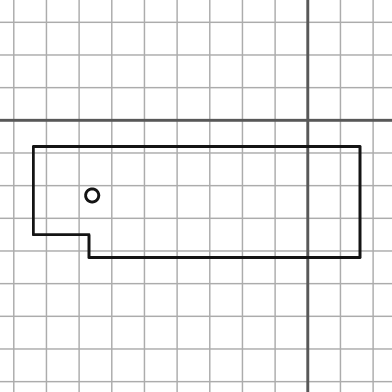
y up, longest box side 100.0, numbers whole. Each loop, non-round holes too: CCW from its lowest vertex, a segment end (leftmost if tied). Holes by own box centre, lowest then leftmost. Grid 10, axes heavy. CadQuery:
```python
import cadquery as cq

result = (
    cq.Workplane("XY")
    .moveTo(-67.0, -42.0)
    .lineTo(16.0, -42.0)
    .lineTo(16.0, -8.0)
    .lineTo(-84.0, -8.0)
    .lineTo(-84.0, -35.0)
    .lineTo(-67.0, -35.0)
    .close()
    .moveTo(-66.0, -23.0)
    .circle(2.0)
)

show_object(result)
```